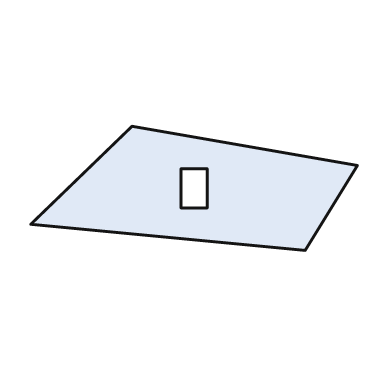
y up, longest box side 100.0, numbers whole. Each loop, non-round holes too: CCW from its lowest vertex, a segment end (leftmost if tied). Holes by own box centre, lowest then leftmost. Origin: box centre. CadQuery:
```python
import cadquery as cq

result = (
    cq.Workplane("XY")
    .moveTo(34.0, -19.0)
    .lineTo(50.0, 7.0)
    .lineTo(-19.0, 19.0)
    .lineTo(-50.0, -11.0)
    .close()
    .moveTo(-4.0, -6.0)
    .lineTo(4.0, -6.0)
    .lineTo(4.0, 6.0)
    .lineTo(-4.0, 6.0)
    .close()
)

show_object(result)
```